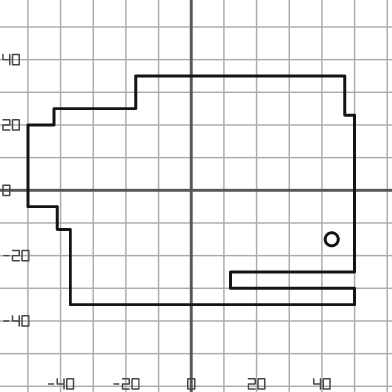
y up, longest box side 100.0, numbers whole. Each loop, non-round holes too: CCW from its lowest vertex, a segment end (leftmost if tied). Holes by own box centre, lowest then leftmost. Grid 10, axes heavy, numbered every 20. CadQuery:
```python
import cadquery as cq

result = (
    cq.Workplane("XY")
    .moveTo(-37.0, -35.0)
    .lineTo(50.0, -35.0)
    .lineTo(50.0, -30.0)
    .lineTo(12.0, -30.0)
    .lineTo(12.0, -25.0)
    .lineTo(50.0, -25.0)
    .lineTo(50.0, 23.0)
    .lineTo(47.0, 23.0)
    .lineTo(47.0, 35.0)
    .lineTo(-17.0, 35.0)
    .lineTo(-17.0, 25.0)
    .lineTo(-42.0, 25.0)
    .lineTo(-42.0, 20.0)
    .lineTo(-50.0, 20.0)
    .lineTo(-50.0, -5.0)
    .lineTo(-41.0, -5.0)
    .lineTo(-41.0, -12.0)
    .lineTo(-37.0, -12.0)
    .close()
    .moveTo(43.0, -15.0)
    .circle(2.0)
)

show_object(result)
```